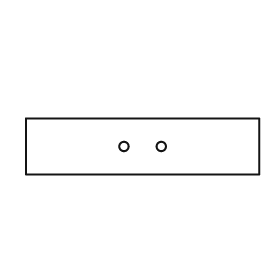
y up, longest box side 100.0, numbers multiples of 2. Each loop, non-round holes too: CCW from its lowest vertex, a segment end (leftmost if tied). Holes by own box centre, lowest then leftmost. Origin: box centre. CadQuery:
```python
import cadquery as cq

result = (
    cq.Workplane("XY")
    .moveTo(-50.0, -12.0)
    .lineTo(50.0, -12.0)
    .lineTo(50.0, 12.0)
    .lineTo(-50.0, 12.0)
    .close()
    .moveTo(-8.0, 0.0)
    .circle(2.0)
    .moveTo(8.0, 0.0)
    .circle(2.0)
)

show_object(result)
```